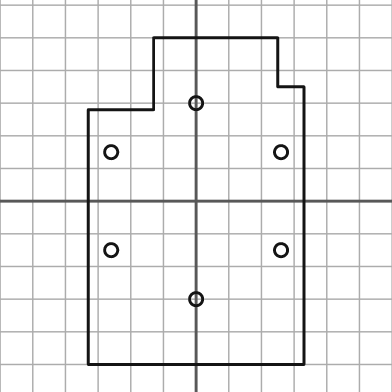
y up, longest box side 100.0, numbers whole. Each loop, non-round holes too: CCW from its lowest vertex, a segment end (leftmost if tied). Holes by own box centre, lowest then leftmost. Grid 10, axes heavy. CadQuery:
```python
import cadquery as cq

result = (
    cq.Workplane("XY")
    .moveTo(-33.0, -50.0)
    .lineTo(33.0, -50.0)
    .lineTo(33.0, 35.0)
    .lineTo(25.0, 35.0)
    .lineTo(25.0, 50.0)
    .lineTo(-13.0, 50.0)
    .lineTo(-13.0, 28.0)
    .lineTo(-33.0, 28.0)
    .close()
    .moveTo(0.0, -30.0)
    .circle(2.0)
    .moveTo(-26.0, -15.0)
    .circle(2.0)
    .moveTo(26.0, -15.0)
    .circle(2.0)
    .moveTo(-26.0, 15.0)
    .circle(2.0)
    .moveTo(26.0, 15.0)
    .circle(2.0)
    .moveTo(0.0, 30.0)
    .circle(2.0)
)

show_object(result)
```